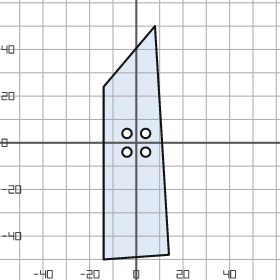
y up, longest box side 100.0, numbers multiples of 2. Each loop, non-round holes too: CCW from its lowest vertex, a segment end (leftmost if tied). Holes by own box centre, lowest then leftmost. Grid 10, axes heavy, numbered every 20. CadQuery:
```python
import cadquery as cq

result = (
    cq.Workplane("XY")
    .moveTo(-14.0, -50.0)
    .lineTo(14.0, -48.0)
    .lineTo(8.0, 50.0)
    .lineTo(-14.0, 24.0)
    .close()
    .moveTo(-4.0, -4.0)
    .circle(2.0)
    .moveTo(4.0, -4.0)
    .circle(2.0)
    .moveTo(-4.0, 4.0)
    .circle(2.0)
    .moveTo(4.0, 4.0)
    .circle(2.0)
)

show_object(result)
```